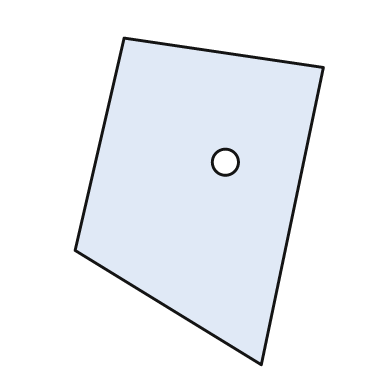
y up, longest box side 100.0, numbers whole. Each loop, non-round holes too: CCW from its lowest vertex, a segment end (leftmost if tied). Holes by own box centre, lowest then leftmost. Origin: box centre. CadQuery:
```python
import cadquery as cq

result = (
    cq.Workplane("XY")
    .moveTo(19.0, -50.0)
    .lineTo(38.0, 41.0)
    .lineTo(-23.0, 50.0)
    .lineTo(-38.0, -15.0)
    .close()
    .moveTo(8.0, 12.0)
    .circle(4.0)
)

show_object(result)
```